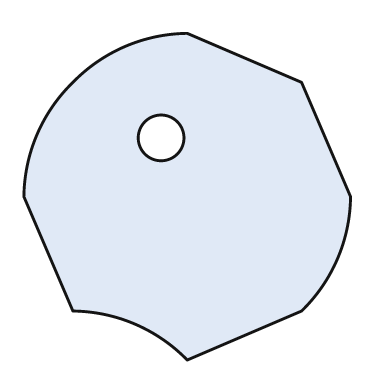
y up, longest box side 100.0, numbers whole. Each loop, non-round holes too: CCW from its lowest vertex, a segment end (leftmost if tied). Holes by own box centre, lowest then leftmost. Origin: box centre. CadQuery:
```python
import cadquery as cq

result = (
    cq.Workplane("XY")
    .moveTo(0.0, -50.0)
    .lineTo(35.0, -35.0)
    .threePointArc((46.0, -19.0), (50.0, 0.0))
    .lineTo(35.0, 35.0)
    .lineTo(0.0, 50.0)
    .threePointArc((-19.0, 46.0), (-35.0, 35.0))
    .threePointArc((-46.0, 19.0), (-50.0, 0.0))
    .lineTo(-35.0, -35.0)
    .threePointArc((-16.0, -39.0), (0.0, -50.0))
    .close()
    .moveTo(-8.0, 18.0)
    .circle(7.0)
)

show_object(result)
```